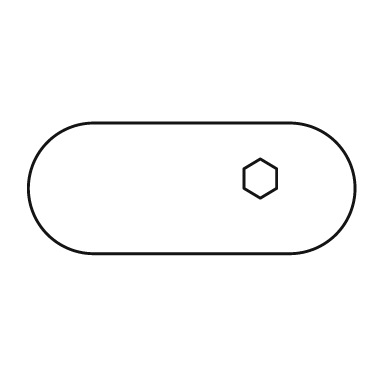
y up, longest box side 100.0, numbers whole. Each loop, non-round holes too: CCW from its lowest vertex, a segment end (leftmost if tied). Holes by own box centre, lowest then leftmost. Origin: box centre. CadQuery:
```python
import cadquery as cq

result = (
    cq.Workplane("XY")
    .moveTo(-30.0, -20.0)
    .lineTo(30.0, -20.0)
    .threePointArc((50.0, 0.0), (30.0, 20.0))
    .lineTo(-30.0, 20.0)
    .threePointArc((-50.0, 0.0), (-30.0, -20.0))
    .close()
    .moveTo(21.0, -3.0)
    .lineTo(26.0, 0.0)
    .lineTo(26.0, 6.0)
    .lineTo(21.0, 9.0)
    .lineTo(16.0, 6.0)
    .lineTo(16.0, 0.0)
    .close()
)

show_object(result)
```